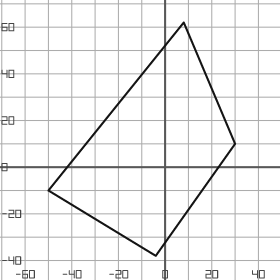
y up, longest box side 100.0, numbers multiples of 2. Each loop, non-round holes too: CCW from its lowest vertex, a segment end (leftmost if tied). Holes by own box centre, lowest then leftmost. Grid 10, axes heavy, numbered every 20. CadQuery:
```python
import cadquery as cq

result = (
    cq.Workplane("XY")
    .moveTo(-4.0, -38.0)
    .lineTo(30.0, 10.0)
    .lineTo(8.0, 62.0)
    .lineTo(-50.0, -10.0)
    .close()
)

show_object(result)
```